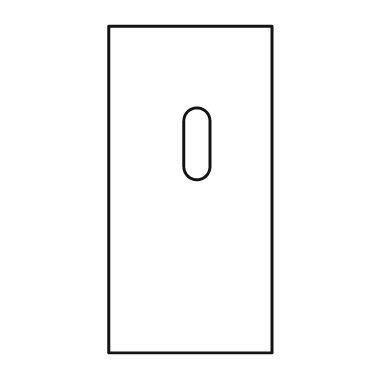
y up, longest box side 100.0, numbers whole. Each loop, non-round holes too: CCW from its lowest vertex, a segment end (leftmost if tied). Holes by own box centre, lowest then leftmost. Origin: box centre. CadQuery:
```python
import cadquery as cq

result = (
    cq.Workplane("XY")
    .moveTo(-25.0, -50.0)
    .lineTo(25.0, -50.0)
    .lineTo(25.0, 50.0)
    .lineTo(-25.0, 50.0)
    .close()
    .moveTo(-2.0, 7.0)
    .threePointArc((2.0, 3.0), (6.0, 7.0))
    .lineTo(6.0, 21.0)
    .threePointArc((2.0, 25.0), (-2.0, 21.0))
    .close()
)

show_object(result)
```